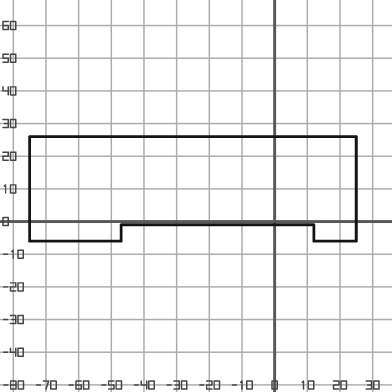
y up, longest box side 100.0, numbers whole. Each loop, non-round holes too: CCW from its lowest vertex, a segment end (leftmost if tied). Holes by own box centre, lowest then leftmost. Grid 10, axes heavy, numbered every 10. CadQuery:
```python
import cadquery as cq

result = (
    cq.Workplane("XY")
    .moveTo(-75.0, -6.0)
    .lineTo(-47.0, -6.0)
    .lineTo(-47.0, -1.0)
    .lineTo(12.0, -1.0)
    .lineTo(12.0, -6.0)
    .lineTo(25.0, -6.0)
    .lineTo(25.0, 26.0)
    .lineTo(-75.0, 26.0)
    .close()
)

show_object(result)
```